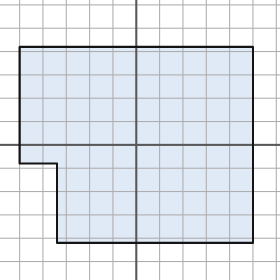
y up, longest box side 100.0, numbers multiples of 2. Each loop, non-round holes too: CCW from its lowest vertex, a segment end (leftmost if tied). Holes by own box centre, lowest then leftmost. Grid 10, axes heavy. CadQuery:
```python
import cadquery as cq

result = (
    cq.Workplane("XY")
    .moveTo(-34.0, -42.0)
    .lineTo(50.0, -42.0)
    .lineTo(50.0, 42.0)
    .lineTo(-50.0, 42.0)
    .lineTo(-50.0, -8.0)
    .lineTo(-34.0, -8.0)
    .close()
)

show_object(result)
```